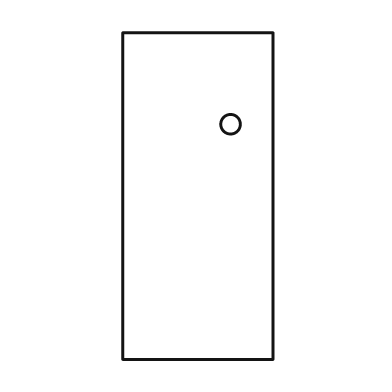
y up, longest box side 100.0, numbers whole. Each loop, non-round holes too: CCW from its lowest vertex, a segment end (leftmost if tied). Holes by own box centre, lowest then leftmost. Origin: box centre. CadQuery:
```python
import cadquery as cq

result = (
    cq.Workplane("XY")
    .moveTo(-23.0, -50.0)
    .lineTo(23.0, -50.0)
    .lineTo(23.0, 50.0)
    .lineTo(-23.0, 50.0)
    .close()
    .moveTo(10.0, 22.0)
    .circle(3.0)
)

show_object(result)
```